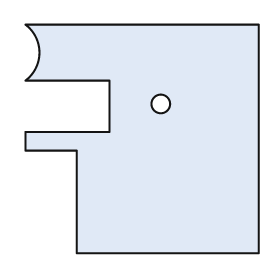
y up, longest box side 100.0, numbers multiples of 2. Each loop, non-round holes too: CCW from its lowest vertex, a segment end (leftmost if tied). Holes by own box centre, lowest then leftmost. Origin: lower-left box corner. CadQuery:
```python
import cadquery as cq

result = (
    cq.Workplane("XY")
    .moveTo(22.0, 0.0)
    .lineTo(100.0, 0.0)
    .lineTo(100.0, 98.0)
    .lineTo(0.0, 98.0)
    .threePointArc((6.0, 86.0), (0.0, 74.0))
    .lineTo(36.0, 74.0)
    .lineTo(36.0, 52.0)
    .lineTo(0.0, 52.0)
    .lineTo(0.0, 44.0)
    .lineTo(22.0, 44.0)
    .close()
    .moveTo(58.0, 64.0)
    .circle(4.0)
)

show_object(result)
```